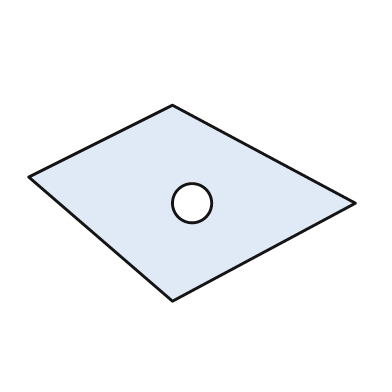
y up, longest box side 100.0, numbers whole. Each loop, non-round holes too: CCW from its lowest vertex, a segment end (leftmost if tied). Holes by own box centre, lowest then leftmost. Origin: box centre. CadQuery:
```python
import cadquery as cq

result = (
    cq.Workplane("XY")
    .moveTo(-6.0, -30.0)
    .lineTo(50.0, 0.0)
    .lineTo(-6.0, 30.0)
    .lineTo(-50.0, 8.0)
    .close()
    .moveTo(0.0, 0.0)
    .circle(6.0)
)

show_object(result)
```